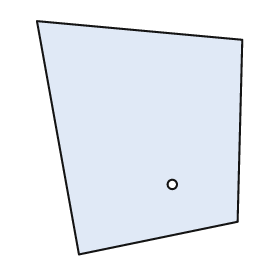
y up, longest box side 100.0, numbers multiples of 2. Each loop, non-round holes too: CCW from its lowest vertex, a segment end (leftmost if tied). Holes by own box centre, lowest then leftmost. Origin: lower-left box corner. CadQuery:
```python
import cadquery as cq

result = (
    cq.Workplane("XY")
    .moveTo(18.0, 0.0)
    .lineTo(86.0, 14.0)
    .lineTo(88.0, 92.0)
    .lineTo(0.0, 100.0)
    .close()
    .moveTo(58.0, 30.0)
    .circle(2.0)
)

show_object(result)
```